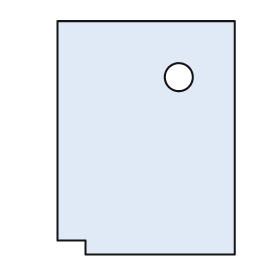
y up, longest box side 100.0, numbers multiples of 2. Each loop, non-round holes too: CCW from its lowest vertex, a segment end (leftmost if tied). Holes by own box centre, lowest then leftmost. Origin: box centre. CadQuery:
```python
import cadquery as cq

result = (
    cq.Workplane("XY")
    .moveTo(-26.0, -50.0)
    .lineTo(38.0, -50.0)
    .lineTo(38.0, 50.0)
    .lineTo(-38.0, 50.0)
    .lineTo(-38.0, -44.0)
    .lineTo(-26.0, -44.0)
    .close()
    .moveTo(14.0, 26.0)
    .circle(6.0)
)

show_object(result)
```